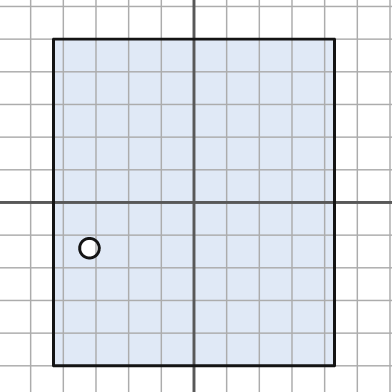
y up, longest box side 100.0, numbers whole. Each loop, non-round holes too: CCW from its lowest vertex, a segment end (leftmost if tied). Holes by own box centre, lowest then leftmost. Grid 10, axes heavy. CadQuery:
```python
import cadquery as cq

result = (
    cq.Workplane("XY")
    .moveTo(-43.0, -50.0)
    .lineTo(43.0, -50.0)
    .lineTo(43.0, 50.0)
    .lineTo(-43.0, 50.0)
    .close()
    .moveTo(-32.0, -14.0)
    .circle(3.0)
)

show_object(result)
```